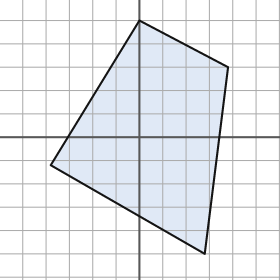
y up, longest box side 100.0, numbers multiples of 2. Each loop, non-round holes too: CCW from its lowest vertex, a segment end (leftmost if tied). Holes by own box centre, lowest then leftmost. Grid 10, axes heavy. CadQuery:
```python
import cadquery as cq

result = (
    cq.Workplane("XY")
    .moveTo(28.0, -50.0)
    .lineTo(38.0, 30.0)
    .lineTo(0.0, 50.0)
    .lineTo(-38.0, -12.0)
    .close()
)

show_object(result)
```